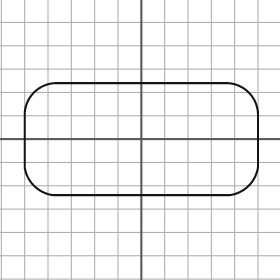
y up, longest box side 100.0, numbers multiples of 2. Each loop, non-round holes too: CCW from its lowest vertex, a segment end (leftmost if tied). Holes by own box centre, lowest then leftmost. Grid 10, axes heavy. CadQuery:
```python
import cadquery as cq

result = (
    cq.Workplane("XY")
    .moveTo(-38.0, -24.0)
    .lineTo(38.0, -24.0)
    .threePointArc((46.0, -20.0), (50.0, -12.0))
    .lineTo(50.0, 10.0)
    .threePointArc((46.0, 20.0), (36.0, 24.0))
    .lineTo(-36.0, 24.0)
    .threePointArc((-46.0, 20.0), (-50.0, 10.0))
    .lineTo(-50.0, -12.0)
    .threePointArc((-46.0, -20.0), (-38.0, -24.0))
    .close()
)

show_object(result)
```